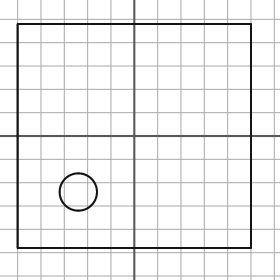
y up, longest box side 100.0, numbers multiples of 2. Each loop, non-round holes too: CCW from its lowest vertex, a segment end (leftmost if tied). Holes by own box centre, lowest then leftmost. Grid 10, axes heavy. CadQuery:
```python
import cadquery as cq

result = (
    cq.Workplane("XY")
    .moveTo(-50.0, -48.0)
    .lineTo(50.0, -48.0)
    .lineTo(50.0, 48.0)
    .lineTo(-50.0, 48.0)
    .close()
    .moveTo(-24.0, -24.0)
    .circle(8.0)
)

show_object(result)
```